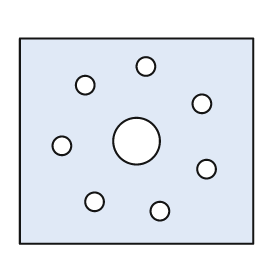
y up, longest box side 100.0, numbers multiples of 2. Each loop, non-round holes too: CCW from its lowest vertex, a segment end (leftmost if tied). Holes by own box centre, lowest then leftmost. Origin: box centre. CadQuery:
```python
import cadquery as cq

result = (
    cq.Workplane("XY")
    .moveTo(-50.0, -44.0)
    .lineTo(50.0, -44.0)
    .lineTo(50.0, 44.0)
    .lineTo(-50.0, 44.0)
    .close()
    .moveTo(10.0, -30.0)
    .circle(4.0)
    .moveTo(-18.0, -26.0)
    .circle(4.0)
    .moveTo(30.0, -12.0)
    .circle(4.0)
    .moveTo(-32.0, -2.0)
    .circle(4.0)
    .moveTo(0.0, 0.0)
    .circle(10.0)
    .moveTo(28.0, 16.0)
    .circle(4.0)
    .moveTo(-22.0, 24.0)
    .circle(4.0)
    .moveTo(4.0, 32.0)
    .circle(4.0)
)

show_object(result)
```